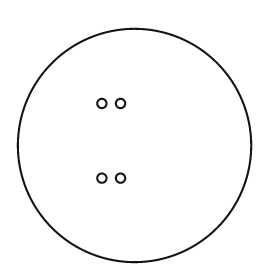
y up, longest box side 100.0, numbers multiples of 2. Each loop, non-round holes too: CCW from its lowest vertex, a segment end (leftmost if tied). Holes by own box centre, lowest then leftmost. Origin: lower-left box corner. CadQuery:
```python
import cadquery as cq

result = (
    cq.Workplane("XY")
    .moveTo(50.0, 50.0)
    .circle(50.0)
    .moveTo(36.0, 36.0)
    .circle(2.0)
    .moveTo(44.0, 36.0)
    .circle(2.0)
    .moveTo(36.0, 68.0)
    .circle(2.0)
    .moveTo(44.0, 68.0)
    .circle(2.0)
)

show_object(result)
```